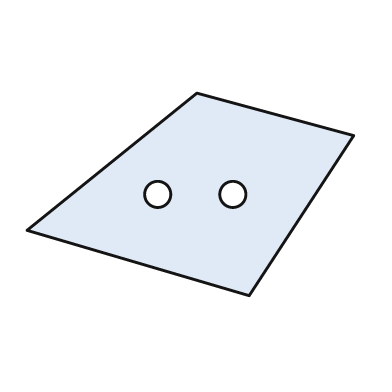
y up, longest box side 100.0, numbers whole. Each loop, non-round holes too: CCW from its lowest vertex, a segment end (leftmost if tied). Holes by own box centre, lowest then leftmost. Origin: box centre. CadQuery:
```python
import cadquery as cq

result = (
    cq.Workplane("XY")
    .moveTo(18.0, -31.0)
    .lineTo(50.0, 18.0)
    .lineTo(2.0, 31.0)
    .lineTo(-50.0, -11.0)
    .close()
    .moveTo(-10.0, 0.0)
    .circle(4.0)
    .moveTo(13.0, 0.0)
    .circle(4.0)
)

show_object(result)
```